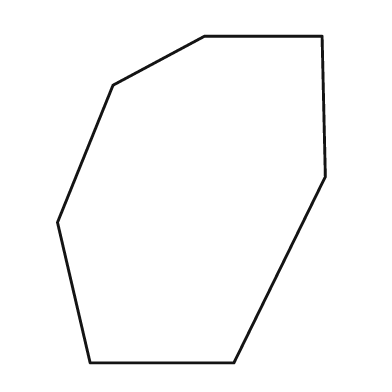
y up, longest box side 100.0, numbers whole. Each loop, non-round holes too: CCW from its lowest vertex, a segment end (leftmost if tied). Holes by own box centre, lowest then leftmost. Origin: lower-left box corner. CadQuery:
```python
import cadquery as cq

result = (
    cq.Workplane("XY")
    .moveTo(10.0, 0.0)
    .lineTo(54.0, 0.0)
    .lineTo(82.0, 57.0)
    .lineTo(81.0, 100.0)
    .lineTo(45.0, 100.0)
    .lineTo(17.0, 85.0)
    .lineTo(0.0, 43.0)
    .close()
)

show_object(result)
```